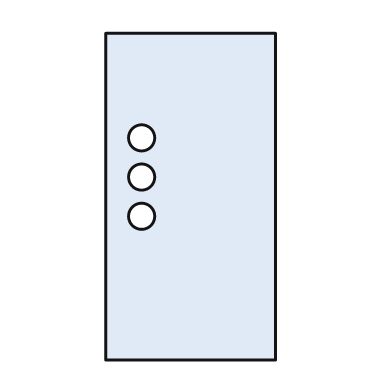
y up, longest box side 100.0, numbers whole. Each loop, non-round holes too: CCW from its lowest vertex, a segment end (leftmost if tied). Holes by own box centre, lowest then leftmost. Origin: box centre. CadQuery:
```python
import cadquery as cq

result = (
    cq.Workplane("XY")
    .moveTo(-26.0, -50.0)
    .lineTo(26.0, -50.0)
    .lineTo(26.0, 50.0)
    .lineTo(-26.0, 50.0)
    .close()
    .moveTo(-15.0, -6.0)
    .circle(4.0)
    .moveTo(-15.0, 6.0)
    .circle(4.0)
    .moveTo(-15.0, 18.0)
    .circle(4.0)
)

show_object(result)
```